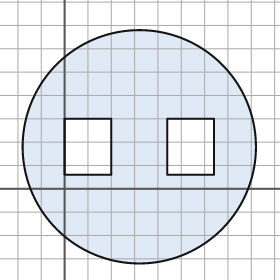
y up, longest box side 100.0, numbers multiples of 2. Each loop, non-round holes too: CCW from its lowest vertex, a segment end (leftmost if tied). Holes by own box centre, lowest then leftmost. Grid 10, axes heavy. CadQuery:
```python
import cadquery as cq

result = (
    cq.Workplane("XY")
    .moveTo(32.0, 18.0)
    .circle(50.0)
    .moveTo(0.0, 6.0)
    .lineTo(20.0, 6.0)
    .lineTo(20.0, 30.0)
    .lineTo(0.0, 30.0)
    .close()
    .moveTo(44.0, 6.0)
    .lineTo(64.0, 6.0)
    .lineTo(64.0, 30.0)
    .lineTo(44.0, 30.0)
    .close()
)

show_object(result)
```